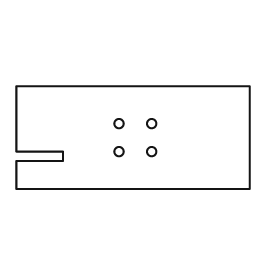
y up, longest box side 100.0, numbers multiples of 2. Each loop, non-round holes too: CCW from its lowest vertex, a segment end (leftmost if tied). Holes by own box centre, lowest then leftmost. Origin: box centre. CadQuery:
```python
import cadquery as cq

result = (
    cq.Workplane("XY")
    .moveTo(-50.0, -22.0)
    .lineTo(50.0, -22.0)
    .lineTo(50.0, 22.0)
    .lineTo(-50.0, 22.0)
    .lineTo(-50.0, -6.0)
    .lineTo(-30.0, -6.0)
    .lineTo(-30.0, -10.0)
    .lineTo(-50.0, -10.0)
    .close()
    .moveTo(-6.0, -6.0)
    .circle(2.0)
    .moveTo(8.0, -6.0)
    .circle(2.0)
    .moveTo(-6.0, 6.0)
    .circle(2.0)
    .moveTo(8.0, 6.0)
    .circle(2.0)
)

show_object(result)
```